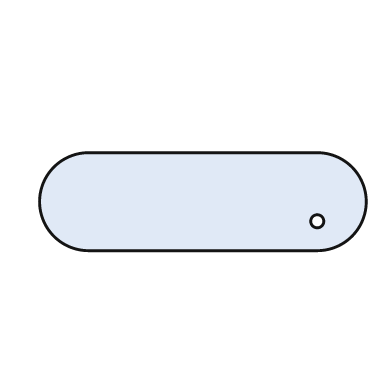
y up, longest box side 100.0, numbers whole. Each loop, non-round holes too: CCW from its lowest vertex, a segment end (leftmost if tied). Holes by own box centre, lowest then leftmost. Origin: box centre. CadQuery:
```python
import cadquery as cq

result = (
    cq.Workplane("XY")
    .moveTo(-35.0, -15.0)
    .lineTo(35.0, -15.0)
    .threePointArc((50.0, 0.0), (35.0, 15.0))
    .lineTo(-35.0, 15.0)
    .threePointArc((-50.0, 0.0), (-35.0, -15.0))
    .close()
    .moveTo(35.0, -6.0)
    .circle(2.0)
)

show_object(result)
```